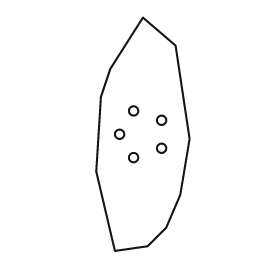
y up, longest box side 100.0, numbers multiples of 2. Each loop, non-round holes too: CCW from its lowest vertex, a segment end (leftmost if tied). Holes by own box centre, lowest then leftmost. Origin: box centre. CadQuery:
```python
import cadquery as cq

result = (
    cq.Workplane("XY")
    .moveTo(-12.0, -50.0)
    .lineTo(2.0, -48.0)
    .lineTo(10.0, -40.0)
    .lineTo(16.0, -26.0)
    .lineTo(20.0, -2.0)
    .lineTo(14.0, 38.0)
    .lineTo(0.0, 50.0)
    .lineTo(-14.0, 28.0)
    .lineTo(-18.0, 16.0)
    .lineTo(-20.0, -16.0)
    .close()
    .moveTo(-4.0, -10.0)
    .circle(2.0)
    .moveTo(8.0, -6.0)
    .circle(2.0)
    .moveTo(-10.0, 0.0)
    .circle(2.0)
    .moveTo(8.0, 6.0)
    .circle(2.0)
    .moveTo(-4.0, 10.0)
    .circle(2.0)
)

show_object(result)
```